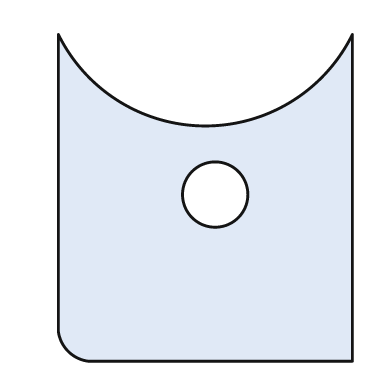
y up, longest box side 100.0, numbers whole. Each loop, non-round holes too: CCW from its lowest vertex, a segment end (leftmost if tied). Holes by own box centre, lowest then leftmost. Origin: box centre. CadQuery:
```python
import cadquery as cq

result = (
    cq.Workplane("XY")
    .moveTo(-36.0, -50.0)
    .lineTo(45.0, -50.0)
    .lineTo(45.0, 50.0)
    .threePointArc((0.0, 22.0), (-45.0, 50.0))
    .lineTo(-45.0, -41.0)
    .threePointArc((-42.0, -47.0), (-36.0, -50.0))
    .close()
    .moveTo(3.0, 1.0)
    .circle(10.0)
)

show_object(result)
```